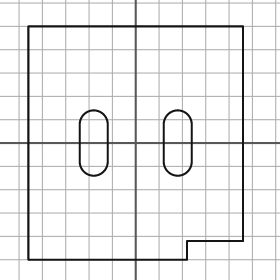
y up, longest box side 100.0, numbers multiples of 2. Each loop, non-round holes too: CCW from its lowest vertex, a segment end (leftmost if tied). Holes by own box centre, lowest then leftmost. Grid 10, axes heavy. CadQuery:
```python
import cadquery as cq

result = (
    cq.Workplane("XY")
    .moveTo(-46.0, -50.0)
    .lineTo(22.0, -50.0)
    .lineTo(22.0, -42.0)
    .lineTo(46.0, -42.0)
    .lineTo(46.0, 50.0)
    .lineTo(-46.0, 50.0)
    .close()
    .moveTo(-24.0, -8.0)
    .threePointArc((-18.0, -14.0), (-12.0, -8.0))
    .lineTo(-12.0, 8.0)
    .threePointArc((-18.0, 14.0), (-24.0, 8.0))
    .close()
    .moveTo(12.0, -8.0)
    .threePointArc((18.0, -14.0), (24.0, -8.0))
    .lineTo(24.0, 8.0)
    .threePointArc((18.0, 14.0), (12.0, 8.0))
    .close()
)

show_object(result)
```